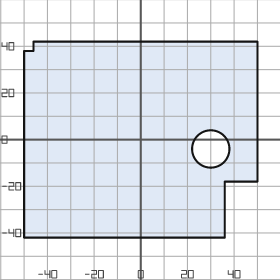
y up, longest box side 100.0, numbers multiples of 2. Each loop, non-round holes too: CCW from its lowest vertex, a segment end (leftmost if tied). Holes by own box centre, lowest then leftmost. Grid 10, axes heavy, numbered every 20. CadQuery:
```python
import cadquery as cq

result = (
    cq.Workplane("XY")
    .moveTo(-50.0, -42.0)
    .lineTo(36.0, -42.0)
    .lineTo(36.0, -18.0)
    .lineTo(50.0, -18.0)
    .lineTo(50.0, 42.0)
    .lineTo(-46.0, 42.0)
    .lineTo(-46.0, 38.0)
    .lineTo(-50.0, 38.0)
    .close()
    .moveTo(30.0, -4.0)
    .circle(8.0)
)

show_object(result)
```